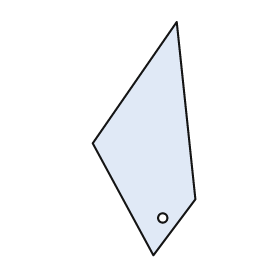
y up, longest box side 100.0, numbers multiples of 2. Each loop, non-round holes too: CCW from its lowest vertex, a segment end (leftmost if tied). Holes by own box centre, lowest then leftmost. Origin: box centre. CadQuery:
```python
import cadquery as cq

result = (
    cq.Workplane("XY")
    .moveTo(4.0, -50.0)
    .lineTo(22.0, -26.0)
    .lineTo(14.0, 50.0)
    .lineTo(-22.0, -2.0)
    .close()
    .moveTo(8.0, -34.0)
    .circle(2.0)
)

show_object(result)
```